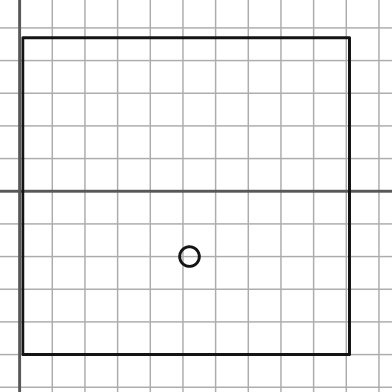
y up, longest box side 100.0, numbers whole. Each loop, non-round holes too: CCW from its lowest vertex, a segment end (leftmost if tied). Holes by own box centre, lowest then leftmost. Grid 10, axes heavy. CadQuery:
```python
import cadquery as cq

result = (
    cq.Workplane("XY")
    .moveTo(1.0, -50.0)
    .lineTo(101.0, -50.0)
    .lineTo(101.0, 47.0)
    .lineTo(1.0, 47.0)
    .close()
    .moveTo(52.0, -20.0)
    .circle(3.0)
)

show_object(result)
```